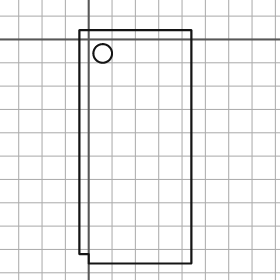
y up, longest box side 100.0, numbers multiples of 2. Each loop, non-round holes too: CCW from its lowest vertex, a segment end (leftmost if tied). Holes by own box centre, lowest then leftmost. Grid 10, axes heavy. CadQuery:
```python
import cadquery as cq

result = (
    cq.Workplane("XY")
    .moveTo(0.0, -96.0)
    .lineTo(44.0, -96.0)
    .lineTo(44.0, 4.0)
    .lineTo(-4.0, 4.0)
    .lineTo(-4.0, -92.0)
    .lineTo(0.0, -92.0)
    .close()
    .moveTo(6.0, -6.0)
    .circle(4.0)
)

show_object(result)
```